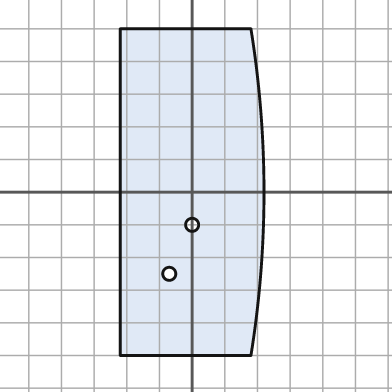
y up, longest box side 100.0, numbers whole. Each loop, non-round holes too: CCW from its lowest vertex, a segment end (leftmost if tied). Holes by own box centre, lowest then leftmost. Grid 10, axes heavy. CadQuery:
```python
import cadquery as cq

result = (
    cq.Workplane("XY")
    .moveTo(-22.0, -50.0)
    .lineTo(18.0, -50.0)
    .threePointArc((22.0, 0.0), (18.0, 50.0))
    .lineTo(-22.0, 50.0)
    .close()
    .moveTo(-7.0, -25.0)
    .circle(2.0)
    .moveTo(0.0, -10.0)
    .circle(2.0)
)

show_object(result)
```